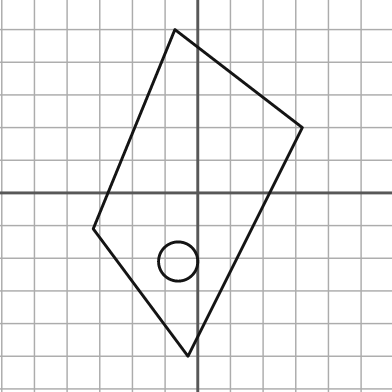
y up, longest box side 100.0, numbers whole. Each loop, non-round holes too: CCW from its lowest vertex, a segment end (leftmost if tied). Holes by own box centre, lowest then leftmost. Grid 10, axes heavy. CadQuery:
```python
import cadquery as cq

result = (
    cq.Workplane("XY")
    .moveTo(-3.0, -50.0)
    .lineTo(32.0, 20.0)
    .lineTo(-7.0, 50.0)
    .lineTo(-32.0, -11.0)
    .close()
    .moveTo(-6.0, -21.0)
    .circle(6.0)
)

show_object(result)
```